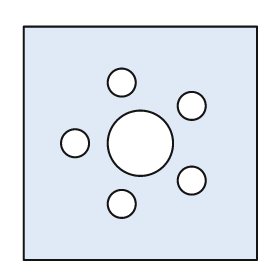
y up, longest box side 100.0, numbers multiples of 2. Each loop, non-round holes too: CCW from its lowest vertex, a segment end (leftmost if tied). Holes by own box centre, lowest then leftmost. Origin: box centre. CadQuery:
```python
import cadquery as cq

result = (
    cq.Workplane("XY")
    .moveTo(-50.0, -50.0)
    .lineTo(50.0, -50.0)
    .lineTo(50.0, 50.0)
    .lineTo(-50.0, 50.0)
    .close()
    .moveTo(-8.0, -26.0)
    .circle(6.0)
    .moveTo(22.0, -16.0)
    .circle(6.0)
    .moveTo(-28.0, 0.0)
    .circle(6.0)
    .moveTo(0.0, 0.0)
    .circle(14.0)
    .moveTo(22.0, 16.0)
    .circle(6.0)
    .moveTo(-8.0, 26.0)
    .circle(6.0)
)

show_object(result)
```